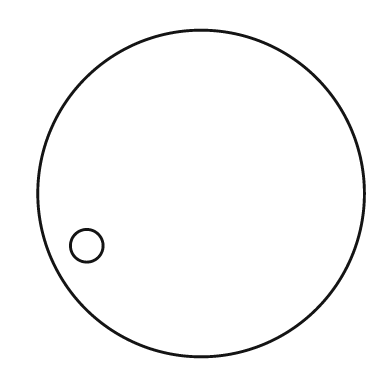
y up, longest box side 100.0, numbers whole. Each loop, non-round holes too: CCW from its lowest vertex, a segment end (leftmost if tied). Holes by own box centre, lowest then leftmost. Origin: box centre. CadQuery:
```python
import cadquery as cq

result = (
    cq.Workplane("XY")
    .moveTo(0.0, 0.0)
    .circle(50.0)
    .moveTo(-35.0, -16.0)
    .circle(5.0)
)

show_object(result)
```